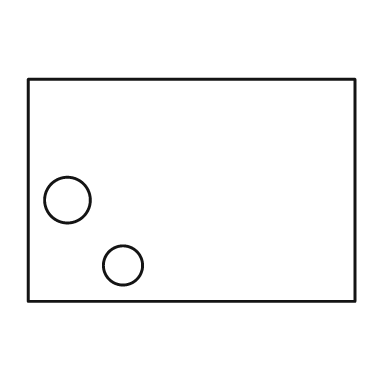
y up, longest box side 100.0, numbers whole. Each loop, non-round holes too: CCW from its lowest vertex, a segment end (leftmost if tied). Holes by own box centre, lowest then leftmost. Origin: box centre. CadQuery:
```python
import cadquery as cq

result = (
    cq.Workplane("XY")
    .moveTo(-50.0, -34.0)
    .lineTo(50.0, -34.0)
    .lineTo(50.0, 34.0)
    .lineTo(-50.0, 34.0)
    .close()
    .moveTo(-21.0, -23.0)
    .circle(6.0)
    .moveTo(-38.0, -3.0)
    .circle(7.0)
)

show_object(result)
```